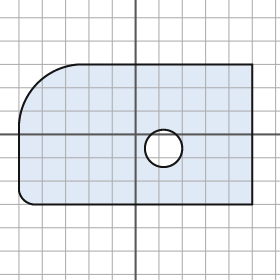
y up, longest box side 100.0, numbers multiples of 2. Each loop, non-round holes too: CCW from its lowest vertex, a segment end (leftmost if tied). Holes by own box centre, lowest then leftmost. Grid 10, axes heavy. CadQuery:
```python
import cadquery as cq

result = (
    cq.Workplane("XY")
    .moveTo(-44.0, -30.0)
    .lineTo(50.0, -30.0)
    .lineTo(50.0, 30.0)
    .lineTo(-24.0, 30.0)
    .threePointArc((-42.0, 22.0), (-50.0, 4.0))
    .lineTo(-50.0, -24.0)
    .threePointArc((-48.0, -28.0), (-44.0, -30.0))
    .close()
    .moveTo(12.0, -6.0)
    .circle(8.0)
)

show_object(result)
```